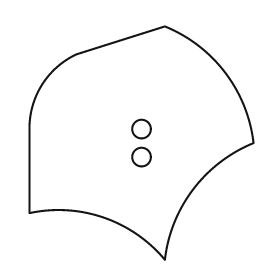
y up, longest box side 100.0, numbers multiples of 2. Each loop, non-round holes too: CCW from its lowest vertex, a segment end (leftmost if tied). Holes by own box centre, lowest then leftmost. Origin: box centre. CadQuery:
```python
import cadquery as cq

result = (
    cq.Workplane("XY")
    .moveTo(10.0, -50.0)
    .threePointArc((22.0, -20.0), (48.0, 0.0))
    .threePointArc((36.0, 30.0), (10.0, 50.0))
    .lineTo(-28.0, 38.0)
    .threePointArc((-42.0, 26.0), (-48.0, 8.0))
    .lineTo(-48.0, -30.0)
    .threePointArc((-16.0, -32.0), (10.0, -50.0))
    .close()
    .moveTo(0.0, -6.0)
    .circle(4.0)
    .moveTo(0.0, 6.0)
    .circle(4.0)
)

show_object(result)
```